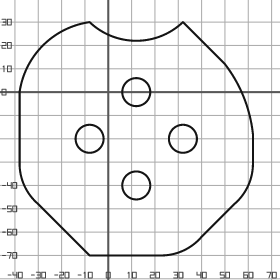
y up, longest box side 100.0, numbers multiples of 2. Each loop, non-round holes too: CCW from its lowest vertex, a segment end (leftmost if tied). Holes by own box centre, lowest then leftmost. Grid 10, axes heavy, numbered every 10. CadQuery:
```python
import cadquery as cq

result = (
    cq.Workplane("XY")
    .moveTo(-8.0, -70.0)
    .lineTo(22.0, -70.0)
    .threePointArc((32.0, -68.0), (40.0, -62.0))
    .lineTo(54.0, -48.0)
    .threePointArc((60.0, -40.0), (62.0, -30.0))
    .lineTo(62.0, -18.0)
    .threePointArc((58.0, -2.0), (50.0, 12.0))
    .lineTo(32.0, 30.0)
    .threePointArc((12.0, 22.0), (-8.0, 30.0))
    .threePointArc((-28.0, 20.0), (-38.0, 0.0))
    .lineTo(-38.0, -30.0)
    .threePointArc((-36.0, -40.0), (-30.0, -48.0))
    .close()
    .moveTo(12.0, -40.0)
    .circle(6.0)
    .moveTo(-8.0, -20.0)
    .circle(6.0)
    .moveTo(32.0, -20.0)
    .circle(6.0)
    .moveTo(12.0, 0.0)
    .circle(6.0)
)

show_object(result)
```